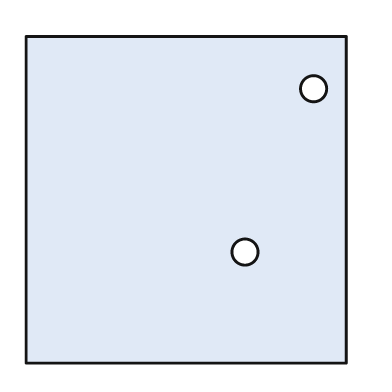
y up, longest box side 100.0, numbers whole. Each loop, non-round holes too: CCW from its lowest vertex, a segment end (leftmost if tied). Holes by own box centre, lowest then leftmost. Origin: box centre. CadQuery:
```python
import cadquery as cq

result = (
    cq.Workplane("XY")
    .moveTo(-49.0, -50.0)
    .lineTo(49.0, -50.0)
    .lineTo(49.0, 50.0)
    .lineTo(-49.0, 50.0)
    .close()
    .moveTo(18.0, -16.0)
    .circle(4.0)
    .moveTo(39.0, 34.0)
    .circle(4.0)
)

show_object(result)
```